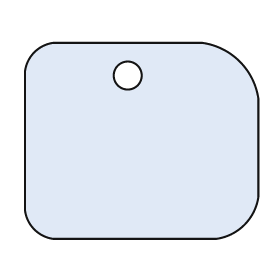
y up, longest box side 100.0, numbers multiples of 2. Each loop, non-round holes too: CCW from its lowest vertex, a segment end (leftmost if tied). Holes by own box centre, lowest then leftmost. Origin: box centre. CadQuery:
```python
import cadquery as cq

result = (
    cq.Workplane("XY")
    .moveTo(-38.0, -42.0)
    .lineTo(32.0, -42.0)
    .threePointArc((44.0, -36.0), (50.0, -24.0))
    .lineTo(50.0, 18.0)
    .threePointArc((42.0, 34.0), (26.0, 42.0))
    .lineTo(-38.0, 42.0)
    .threePointArc((-46.0, 38.0), (-50.0, 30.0))
    .lineTo(-50.0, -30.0)
    .threePointArc((-46.0, -38.0), (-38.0, -42.0))
    .close()
    .moveTo(-6.0, 28.0)
    .circle(6.0)
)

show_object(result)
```